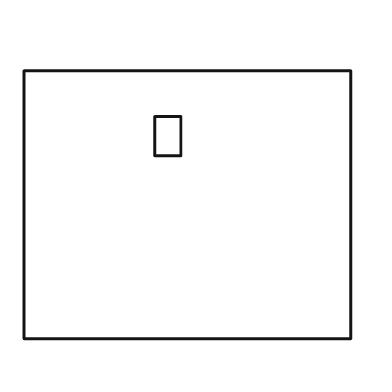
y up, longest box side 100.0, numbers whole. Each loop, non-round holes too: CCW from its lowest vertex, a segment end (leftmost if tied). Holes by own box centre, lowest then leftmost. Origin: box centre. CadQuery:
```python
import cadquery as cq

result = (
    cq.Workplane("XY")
    .moveTo(-50.0, -41.0)
    .lineTo(50.0, -41.0)
    .lineTo(50.0, 41.0)
    .lineTo(-50.0, 41.0)
    .close()
    .moveTo(-10.0, 15.0)
    .lineTo(-2.0, 15.0)
    .lineTo(-2.0, 27.0)
    .lineTo(-10.0, 27.0)
    .close()
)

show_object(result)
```